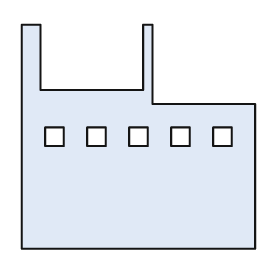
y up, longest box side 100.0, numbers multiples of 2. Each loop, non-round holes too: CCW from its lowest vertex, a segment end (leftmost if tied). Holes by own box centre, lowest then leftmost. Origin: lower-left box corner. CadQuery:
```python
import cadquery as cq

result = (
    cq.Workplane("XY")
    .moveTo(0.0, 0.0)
    .lineTo(100.0, 0.0)
    .lineTo(100.0, 62.0)
    .lineTo(56.0, 62.0)
    .lineTo(56.0, 96.0)
    .lineTo(52.0, 96.0)
    .lineTo(52.0, 68.0)
    .lineTo(8.0, 68.0)
    .lineTo(8.0, 96.0)
    .lineTo(0.0, 96.0)
    .close()
    .moveTo(10.0, 44.0)
    .lineTo(18.0, 44.0)
    .lineTo(18.0, 52.0)
    .lineTo(10.0, 52.0)
    .close()
    .moveTo(28.0, 44.0)
    .lineTo(36.0, 44.0)
    .lineTo(36.0, 52.0)
    .lineTo(28.0, 52.0)
    .close()
    .moveTo(46.0, 44.0)
    .lineTo(54.0, 44.0)
    .lineTo(54.0, 52.0)
    .lineTo(46.0, 52.0)
    .close()
    .moveTo(64.0, 44.0)
    .lineTo(72.0, 44.0)
    .lineTo(72.0, 52.0)
    .lineTo(64.0, 52.0)
    .close()
    .moveTo(82.0, 44.0)
    .lineTo(90.0, 44.0)
    .lineTo(90.0, 52.0)
    .lineTo(82.0, 52.0)
    .close()
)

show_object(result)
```